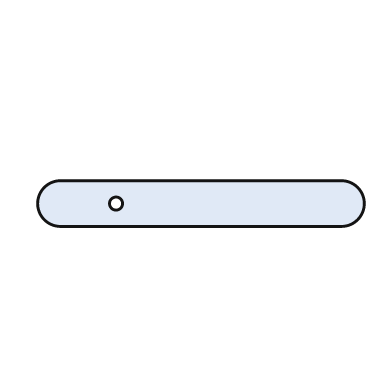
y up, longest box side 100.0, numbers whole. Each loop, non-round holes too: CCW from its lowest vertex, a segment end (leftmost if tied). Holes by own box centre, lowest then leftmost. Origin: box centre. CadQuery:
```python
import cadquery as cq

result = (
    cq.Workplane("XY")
    .moveTo(-43.0, -7.0)
    .lineTo(43.0, -7.0)
    .threePointArc((50.0, 0.0), (43.0, 7.0))
    .lineTo(-43.0, 7.0)
    .threePointArc((-50.0, 0.0), (-43.0, -7.0))
    .close()
    .moveTo(-26.0, 0.0)
    .circle(2.0)
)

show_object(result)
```